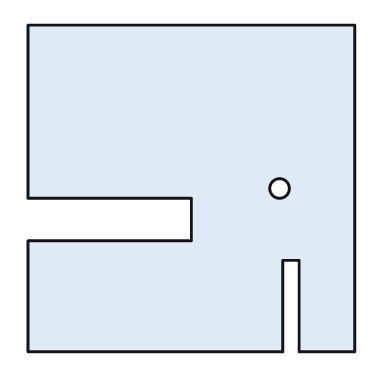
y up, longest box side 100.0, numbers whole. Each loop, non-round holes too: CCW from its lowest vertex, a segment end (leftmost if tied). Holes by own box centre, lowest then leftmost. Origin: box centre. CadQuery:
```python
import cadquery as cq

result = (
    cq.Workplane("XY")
    .moveTo(-50.0, -50.0)
    .lineTo(28.0, -50.0)
    .lineTo(28.0, -22.0)
    .lineTo(33.0, -22.0)
    .lineTo(33.0, -50.0)
    .lineTo(50.0, -50.0)
    .lineTo(50.0, 50.0)
    .lineTo(-50.0, 50.0)
    .lineTo(-50.0, -3.0)
    .lineTo(0.0, -3.0)
    .lineTo(0.0, -16.0)
    .lineTo(-50.0, -16.0)
    .close()
    .moveTo(27.0, 0.0)
    .circle(3.0)
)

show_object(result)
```